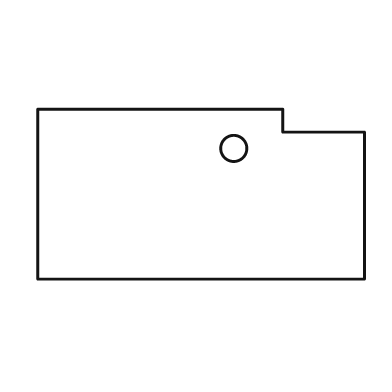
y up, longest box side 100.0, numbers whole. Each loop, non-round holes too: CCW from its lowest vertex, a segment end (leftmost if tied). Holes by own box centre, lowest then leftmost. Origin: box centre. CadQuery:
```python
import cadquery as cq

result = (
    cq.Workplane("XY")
    .moveTo(-50.0, -26.0)
    .lineTo(50.0, -26.0)
    .lineTo(50.0, 19.0)
    .lineTo(25.0, 19.0)
    .lineTo(25.0, 26.0)
    .lineTo(-50.0, 26.0)
    .close()
    .moveTo(10.0, 14.0)
    .circle(4.0)
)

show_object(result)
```